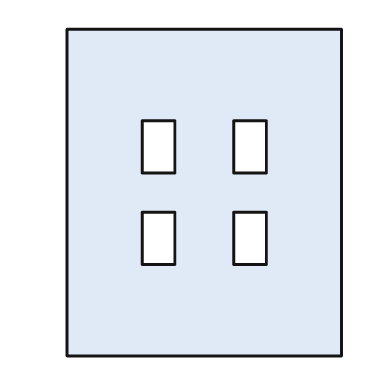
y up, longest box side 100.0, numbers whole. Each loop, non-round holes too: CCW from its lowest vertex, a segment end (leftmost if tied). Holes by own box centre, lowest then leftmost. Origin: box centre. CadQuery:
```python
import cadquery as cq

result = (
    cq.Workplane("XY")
    .moveTo(-42.0, -50.0)
    .lineTo(42.0, -50.0)
    .lineTo(42.0, 50.0)
    .lineTo(-42.0, 50.0)
    .close()
    .moveTo(-19.0, -22.0)
    .lineTo(-9.0, -22.0)
    .lineTo(-9.0, -6.0)
    .lineTo(-19.0, -6.0)
    .close()
    .moveTo(9.0, -22.0)
    .lineTo(19.0, -22.0)
    .lineTo(19.0, -6.0)
    .lineTo(9.0, -6.0)
    .close()
    .moveTo(-19.0, 6.0)
    .lineTo(-9.0, 6.0)
    .lineTo(-9.0, 22.0)
    .lineTo(-19.0, 22.0)
    .close()
    .moveTo(9.0, 6.0)
    .lineTo(19.0, 6.0)
    .lineTo(19.0, 22.0)
    .lineTo(9.0, 22.0)
    .close()
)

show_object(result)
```